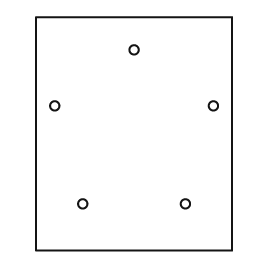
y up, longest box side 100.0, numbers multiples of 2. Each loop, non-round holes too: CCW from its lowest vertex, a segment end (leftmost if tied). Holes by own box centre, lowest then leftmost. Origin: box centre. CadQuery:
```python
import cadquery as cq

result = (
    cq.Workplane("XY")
    .moveTo(-42.0, -50.0)
    .lineTo(42.0, -50.0)
    .lineTo(42.0, 50.0)
    .lineTo(-42.0, 50.0)
    .close()
    .moveTo(-22.0, -30.0)
    .circle(2.0)
    .moveTo(22.0, -30.0)
    .circle(2.0)
    .moveTo(-34.0, 12.0)
    .circle(2.0)
    .moveTo(34.0, 12.0)
    .circle(2.0)
    .moveTo(0.0, 36.0)
    .circle(2.0)
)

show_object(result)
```